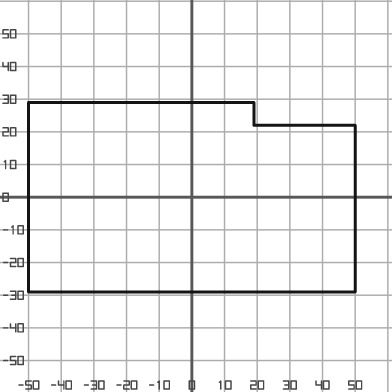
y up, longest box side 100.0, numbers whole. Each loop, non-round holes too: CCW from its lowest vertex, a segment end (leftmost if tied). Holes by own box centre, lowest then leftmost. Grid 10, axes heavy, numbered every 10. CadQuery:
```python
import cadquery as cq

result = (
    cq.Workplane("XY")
    .moveTo(-50.0, -29.0)
    .lineTo(50.0, -29.0)
    .lineTo(50.0, 22.0)
    .lineTo(19.0, 22.0)
    .lineTo(19.0, 29.0)
    .lineTo(-50.0, 29.0)
    .close()
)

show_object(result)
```